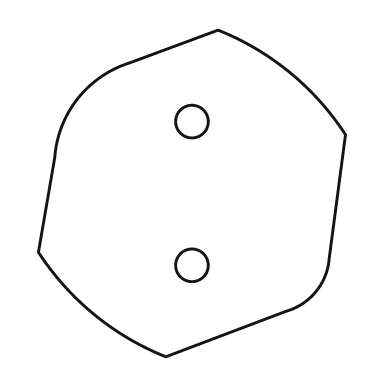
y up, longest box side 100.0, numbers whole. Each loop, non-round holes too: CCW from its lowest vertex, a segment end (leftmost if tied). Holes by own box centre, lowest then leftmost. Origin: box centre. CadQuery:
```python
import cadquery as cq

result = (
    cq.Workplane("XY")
    .moveTo(-8.0, -50.0)
    .lineTo(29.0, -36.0)
    .threePointArc((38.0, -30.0), (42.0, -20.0))
    .lineTo(47.0, 18.0)
    .threePointArc((30.0, 37.0), (8.0, 50.0))
    .lineTo(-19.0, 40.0)
    .threePointArc((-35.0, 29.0), (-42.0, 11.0))
    .lineTo(-47.0, -18.0)
    .threePointArc((-30.0, -37.0), (-8.0, -50.0))
    .close()
    .moveTo(0.0, -22.0)
    .circle(5.0)
    .moveTo(0.0, 22.0)
    .circle(5.0)
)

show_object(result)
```